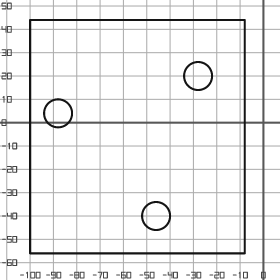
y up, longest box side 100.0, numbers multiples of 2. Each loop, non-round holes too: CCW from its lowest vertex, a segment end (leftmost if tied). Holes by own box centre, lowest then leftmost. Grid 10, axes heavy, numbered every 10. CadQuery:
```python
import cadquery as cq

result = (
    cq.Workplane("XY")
    .moveTo(-100.0, -56.0)
    .lineTo(-8.0, -56.0)
    .lineTo(-8.0, 44.0)
    .lineTo(-100.0, 44.0)
    .close()
    .moveTo(-46.0, -40.0)
    .circle(6.0)
    .moveTo(-88.0, 4.0)
    .circle(6.0)
    .moveTo(-28.0, 20.0)
    .circle(6.0)
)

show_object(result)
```